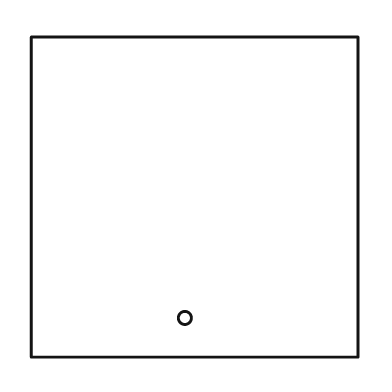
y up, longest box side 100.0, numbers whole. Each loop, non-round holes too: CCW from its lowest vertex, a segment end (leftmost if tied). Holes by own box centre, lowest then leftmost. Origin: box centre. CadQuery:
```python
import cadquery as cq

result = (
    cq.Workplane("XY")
    .moveTo(-50.0, -49.0)
    .lineTo(50.0, -49.0)
    .lineTo(50.0, 49.0)
    .lineTo(-50.0, 49.0)
    .close()
    .moveTo(-3.0, -37.0)
    .circle(2.0)
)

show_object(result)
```